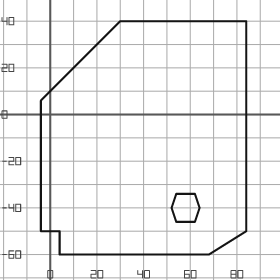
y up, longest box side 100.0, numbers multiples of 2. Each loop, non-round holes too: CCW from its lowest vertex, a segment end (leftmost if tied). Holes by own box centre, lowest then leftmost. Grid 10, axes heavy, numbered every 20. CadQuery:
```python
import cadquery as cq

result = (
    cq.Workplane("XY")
    .moveTo(4.0, -60.0)
    .lineTo(68.0, -60.0)
    .lineTo(84.0, -50.0)
    .lineTo(84.0, 40.0)
    .lineTo(30.0, 40.0)
    .lineTo(-4.0, 6.0)
    .lineTo(-4.0, -50.0)
    .lineTo(4.0, -50.0)
    .close()
    .moveTo(54.0, -46.0)
    .lineTo(62.0, -46.0)
    .lineTo(64.0, -40.0)
    .lineTo(62.0, -34.0)
    .lineTo(54.0, -34.0)
    .lineTo(52.0, -40.0)
    .close()
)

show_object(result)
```